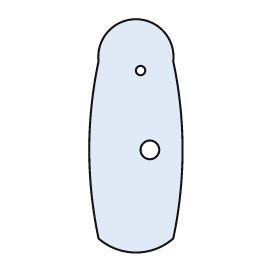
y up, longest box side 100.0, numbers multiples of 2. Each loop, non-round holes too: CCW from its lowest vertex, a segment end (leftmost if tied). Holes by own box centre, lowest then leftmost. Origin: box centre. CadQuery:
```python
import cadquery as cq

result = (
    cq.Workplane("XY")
    .moveTo(-16.0, -44.0)
    .threePointArc((0.0, -50.0), (16.0, -44.0))
    .threePointArc((20.0, -6.0), (16.0, 32.0))
    .threePointArc((0.0, 50.0), (-16.0, 32.0))
    .threePointArc((-20.0, -6.0), (-16.0, -44.0))
    .close()
    .moveTo(6.0, -6.0)
    .circle(4.0)
    .moveTo(2.0, 28.0)
    .circle(2.0)
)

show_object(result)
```